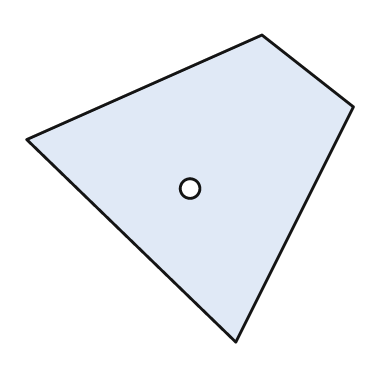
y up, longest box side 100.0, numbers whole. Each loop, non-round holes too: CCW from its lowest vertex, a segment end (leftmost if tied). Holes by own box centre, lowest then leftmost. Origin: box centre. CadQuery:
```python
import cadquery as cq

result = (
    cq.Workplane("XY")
    .moveTo(14.0, -47.0)
    .lineTo(50.0, 25.0)
    .lineTo(22.0, 47.0)
    .lineTo(-50.0, 15.0)
    .close()
    .moveTo(0.0, 0.0)
    .circle(3.0)
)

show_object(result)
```